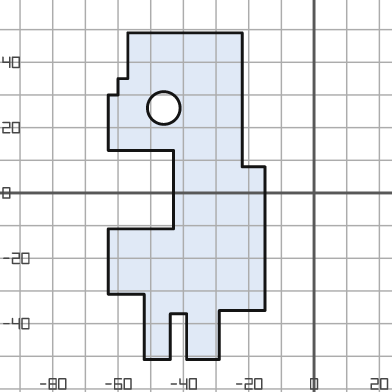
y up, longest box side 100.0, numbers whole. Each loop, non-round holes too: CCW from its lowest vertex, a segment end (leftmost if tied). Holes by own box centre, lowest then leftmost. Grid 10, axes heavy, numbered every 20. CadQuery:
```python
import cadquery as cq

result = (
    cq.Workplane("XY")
    .moveTo(-52.0, -51.0)
    .lineTo(-44.0, -51.0)
    .lineTo(-44.0, -37.0)
    .lineTo(-39.0, -37.0)
    .lineTo(-39.0, -51.0)
    .lineTo(-29.0, -51.0)
    .lineTo(-29.0, -36.0)
    .lineTo(-15.0, -36.0)
    .lineTo(-15.0, 8.0)
    .lineTo(-22.0, 8.0)
    .lineTo(-22.0, 49.0)
    .lineTo(-57.0, 49.0)
    .lineTo(-57.0, 35.0)
    .lineTo(-60.0, 35.0)
    .lineTo(-60.0, 30.0)
    .lineTo(-63.0, 30.0)
    .lineTo(-63.0, 13.0)
    .lineTo(-43.0, 13.0)
    .lineTo(-43.0, -11.0)
    .lineTo(-63.0, -11.0)
    .lineTo(-63.0, -31.0)
    .lineTo(-52.0, -31.0)
    .close()
    .moveTo(-46.0, 26.0)
    .circle(5.0)
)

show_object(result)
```